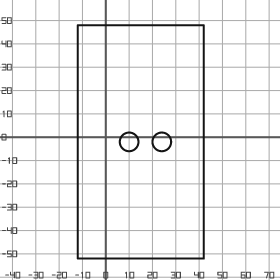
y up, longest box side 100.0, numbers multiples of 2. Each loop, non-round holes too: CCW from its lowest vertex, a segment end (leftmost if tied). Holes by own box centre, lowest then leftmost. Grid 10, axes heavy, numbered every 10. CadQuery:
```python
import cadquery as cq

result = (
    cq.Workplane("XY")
    .moveTo(-12.0, -52.0)
    .lineTo(42.0, -52.0)
    .lineTo(42.0, 48.0)
    .lineTo(-12.0, 48.0)
    .close()
    .moveTo(10.0, -2.0)
    .circle(4.0)
    .moveTo(24.0, -2.0)
    .circle(4.0)
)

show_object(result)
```